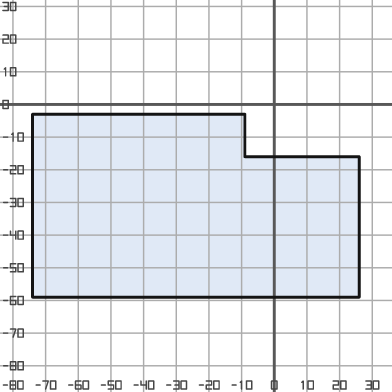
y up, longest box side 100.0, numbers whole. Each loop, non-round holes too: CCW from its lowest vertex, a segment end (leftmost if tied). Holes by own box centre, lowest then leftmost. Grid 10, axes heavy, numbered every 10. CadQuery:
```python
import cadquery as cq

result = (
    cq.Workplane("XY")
    .moveTo(-74.0, -59.0)
    .lineTo(26.0, -59.0)
    .lineTo(26.0, -16.0)
    .lineTo(-9.0, -16.0)
    .lineTo(-9.0, -3.0)
    .lineTo(-74.0, -3.0)
    .close()
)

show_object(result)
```